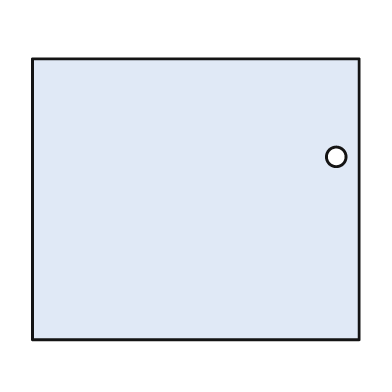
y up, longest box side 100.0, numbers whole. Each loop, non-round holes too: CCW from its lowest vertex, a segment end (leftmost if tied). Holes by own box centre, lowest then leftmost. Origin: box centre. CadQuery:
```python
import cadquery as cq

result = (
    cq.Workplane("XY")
    .moveTo(-50.0, -43.0)
    .lineTo(50.0, -43.0)
    .lineTo(50.0, 43.0)
    .lineTo(-50.0, 43.0)
    .close()
    .moveTo(43.0, 13.0)
    .circle(3.0)
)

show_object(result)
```